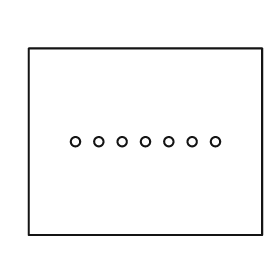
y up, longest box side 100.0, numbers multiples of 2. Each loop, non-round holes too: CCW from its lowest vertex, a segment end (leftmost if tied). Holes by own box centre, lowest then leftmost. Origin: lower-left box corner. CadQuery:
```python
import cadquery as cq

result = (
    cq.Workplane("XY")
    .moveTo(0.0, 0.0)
    .lineTo(100.0, 0.0)
    .lineTo(100.0, 80.0)
    .lineTo(0.0, 80.0)
    .close()
    .moveTo(20.0, 40.0)
    .circle(2.0)
    .moveTo(30.0, 40.0)
    .circle(2.0)
    .moveTo(40.0, 40.0)
    .circle(2.0)
    .moveTo(50.0, 40.0)
    .circle(2.0)
    .moveTo(60.0, 40.0)
    .circle(2.0)
    .moveTo(70.0, 40.0)
    .circle(2.0)
    .moveTo(80.0, 40.0)
    .circle(2.0)
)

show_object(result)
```